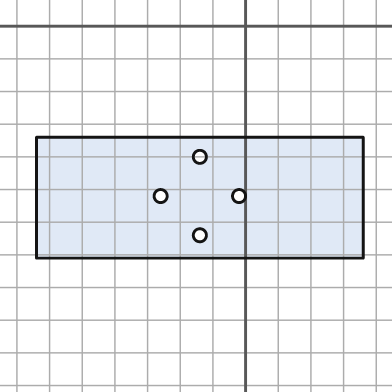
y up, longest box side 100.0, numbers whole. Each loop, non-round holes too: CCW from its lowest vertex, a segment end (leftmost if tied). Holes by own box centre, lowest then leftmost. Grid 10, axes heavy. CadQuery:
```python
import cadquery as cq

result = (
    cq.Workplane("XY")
    .moveTo(-64.0, -71.0)
    .lineTo(36.0, -71.0)
    .lineTo(36.0, -34.0)
    .lineTo(-64.0, -34.0)
    .close()
    .moveTo(-14.0, -64.0)
    .circle(2.0)
    .moveTo(-26.0, -52.0)
    .circle(2.0)
    .moveTo(-2.0, -52.0)
    .circle(2.0)
    .moveTo(-14.0, -40.0)
    .circle(2.0)
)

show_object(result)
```